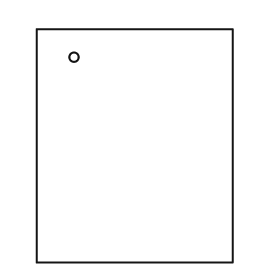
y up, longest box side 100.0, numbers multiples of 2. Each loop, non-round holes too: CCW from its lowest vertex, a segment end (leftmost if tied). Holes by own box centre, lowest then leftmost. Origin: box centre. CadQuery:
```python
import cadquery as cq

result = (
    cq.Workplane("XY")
    .moveTo(-42.0, -50.0)
    .lineTo(42.0, -50.0)
    .lineTo(42.0, 50.0)
    .lineTo(-42.0, 50.0)
    .close()
    .moveTo(-26.0, 38.0)
    .circle(2.0)
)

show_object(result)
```